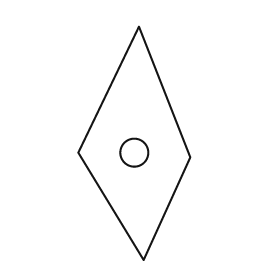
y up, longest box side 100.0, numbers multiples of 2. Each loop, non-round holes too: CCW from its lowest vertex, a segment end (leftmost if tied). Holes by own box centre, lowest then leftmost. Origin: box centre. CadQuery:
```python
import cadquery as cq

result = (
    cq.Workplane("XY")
    .moveTo(4.0, -50.0)
    .lineTo(24.0, -6.0)
    .lineTo(2.0, 50.0)
    .lineTo(-24.0, -4.0)
    .close()
    .moveTo(0.0, -4.0)
    .circle(6.0)
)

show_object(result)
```